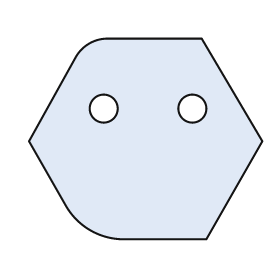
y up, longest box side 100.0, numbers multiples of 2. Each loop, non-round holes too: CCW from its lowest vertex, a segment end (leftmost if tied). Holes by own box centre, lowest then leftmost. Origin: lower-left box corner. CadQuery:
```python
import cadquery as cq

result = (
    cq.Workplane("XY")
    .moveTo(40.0, 0.0)
    .lineTo(76.0, 0.0)
    .lineTo(100.0, 42.0)
    .lineTo(74.0, 86.0)
    .lineTo(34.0, 86.0)
    .threePointArc((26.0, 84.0), (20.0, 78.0))
    .lineTo(0.0, 42.0)
    .lineTo(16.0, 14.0)
    .threePointArc((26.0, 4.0), (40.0, 0.0))
    .close()
    .moveTo(32.0, 56.0)
    .circle(6.0)
    .moveTo(70.0, 56.0)
    .circle(6.0)
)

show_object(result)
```